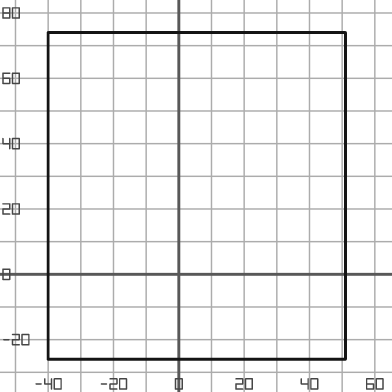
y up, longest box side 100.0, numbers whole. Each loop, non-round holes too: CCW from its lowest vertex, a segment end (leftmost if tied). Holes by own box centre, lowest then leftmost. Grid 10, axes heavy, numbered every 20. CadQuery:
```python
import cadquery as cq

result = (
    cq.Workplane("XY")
    .moveTo(-40.0, -26.0)
    .lineTo(51.0, -26.0)
    .lineTo(51.0, 74.0)
    .lineTo(-40.0, 74.0)
    .close()
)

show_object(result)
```